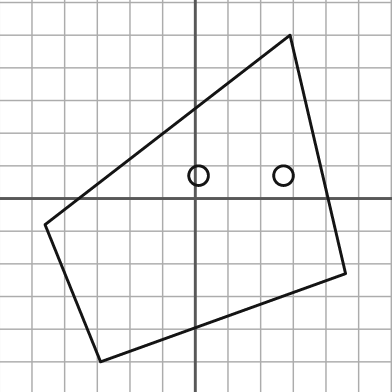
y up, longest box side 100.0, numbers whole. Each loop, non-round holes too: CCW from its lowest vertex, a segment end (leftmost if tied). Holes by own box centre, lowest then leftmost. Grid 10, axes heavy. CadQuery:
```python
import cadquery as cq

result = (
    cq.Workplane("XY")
    .moveTo(-29.0, -50.0)
    .lineTo(46.0, -23.0)
    .lineTo(29.0, 50.0)
    .lineTo(-46.0, -8.0)
    .close()
    .moveTo(1.0, 7.0)
    .circle(3.0)
    .moveTo(27.0, 7.0)
    .circle(3.0)
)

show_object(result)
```